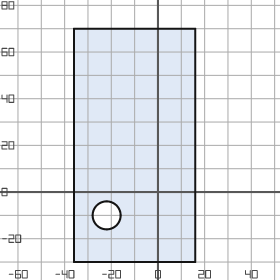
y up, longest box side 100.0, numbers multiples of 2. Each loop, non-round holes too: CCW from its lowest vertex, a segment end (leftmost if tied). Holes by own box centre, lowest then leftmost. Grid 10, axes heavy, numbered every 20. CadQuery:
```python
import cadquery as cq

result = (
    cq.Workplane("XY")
    .moveTo(-36.0, -30.0)
    .lineTo(16.0, -30.0)
    .lineTo(16.0, 70.0)
    .lineTo(-36.0, 70.0)
    .close()
    .moveTo(-22.0, -10.0)
    .circle(6.0)
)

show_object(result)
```